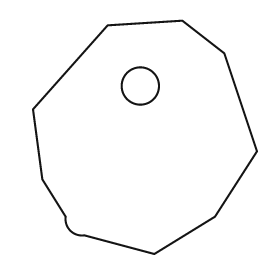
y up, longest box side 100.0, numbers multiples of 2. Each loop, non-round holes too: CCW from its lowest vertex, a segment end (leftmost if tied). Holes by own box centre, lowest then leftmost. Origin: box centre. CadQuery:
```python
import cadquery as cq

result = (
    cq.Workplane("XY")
    .moveTo(4.0, -50.0)
    .lineTo(30.0, -34.0)
    .lineTo(48.0, -6.0)
    .lineTo(34.0, 36.0)
    .lineTo(16.0, 50.0)
    .lineTo(-16.0, 48.0)
    .lineTo(-48.0, 12.0)
    .lineTo(-44.0, -18.0)
    .lineTo(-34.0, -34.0)
    .threePointArc((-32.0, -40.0), (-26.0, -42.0))
    .close()
    .moveTo(-2.0, 22.0)
    .circle(8.0)
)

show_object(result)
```